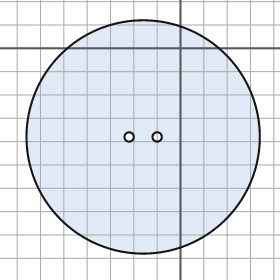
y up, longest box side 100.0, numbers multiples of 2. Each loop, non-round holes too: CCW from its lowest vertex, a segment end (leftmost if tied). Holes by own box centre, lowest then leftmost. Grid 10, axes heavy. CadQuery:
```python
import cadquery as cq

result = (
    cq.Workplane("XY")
    .moveTo(-16.0, -38.0)
    .circle(50.0)
    .moveTo(-22.0, -38.0)
    .circle(2.0)
    .moveTo(-10.0, -38.0)
    .circle(2.0)
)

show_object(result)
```